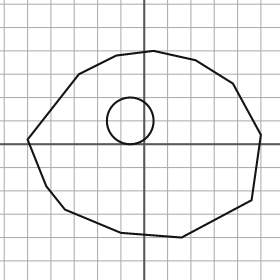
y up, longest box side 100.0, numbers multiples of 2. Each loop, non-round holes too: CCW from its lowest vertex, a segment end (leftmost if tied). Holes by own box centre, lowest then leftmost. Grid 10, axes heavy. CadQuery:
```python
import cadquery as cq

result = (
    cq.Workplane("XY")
    .moveTo(16.0, -40.0)
    .lineTo(46.0, -24.0)
    .lineTo(50.0, 4.0)
    .lineTo(38.0, 26.0)
    .lineTo(22.0, 36.0)
    .lineTo(4.0, 40.0)
    .lineTo(-12.0, 38.0)
    .lineTo(-28.0, 30.0)
    .lineTo(-50.0, 2.0)
    .lineTo(-42.0, -18.0)
    .lineTo(-34.0, -28.0)
    .lineTo(-10.0, -38.0)
    .close()
    .moveTo(-6.0, 10.0)
    .circle(10.0)
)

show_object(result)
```